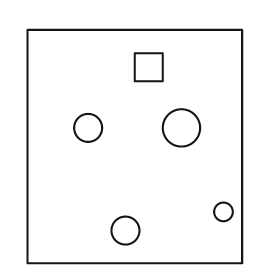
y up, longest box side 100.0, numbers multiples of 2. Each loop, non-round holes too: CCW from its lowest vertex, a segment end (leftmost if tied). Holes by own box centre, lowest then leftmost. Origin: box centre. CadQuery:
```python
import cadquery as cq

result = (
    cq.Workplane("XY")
    .moveTo(-46.0, -50.0)
    .lineTo(46.0, -50.0)
    .lineTo(46.0, 50.0)
    .lineTo(-46.0, 50.0)
    .close()
    .moveTo(-4.0, -36.0)
    .circle(6.0)
    .moveTo(38.0, -28.0)
    .circle(4.0)
    .moveTo(-20.0, 8.0)
    .circle(6.0)
    .moveTo(20.0, 8.0)
    .circle(8.0)
    .moveTo(0.0, 28.0)
    .lineTo(12.0, 28.0)
    .lineTo(12.0, 40.0)
    .lineTo(0.0, 40.0)
    .close()
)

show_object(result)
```